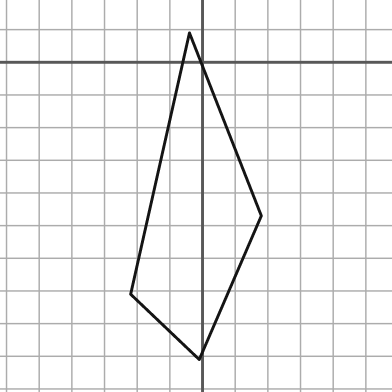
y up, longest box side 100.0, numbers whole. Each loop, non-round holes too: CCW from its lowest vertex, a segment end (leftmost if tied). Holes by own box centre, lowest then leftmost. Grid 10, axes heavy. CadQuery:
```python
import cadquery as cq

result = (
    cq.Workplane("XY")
    .moveTo(-1.0, -91.0)
    .lineTo(18.0, -47.0)
    .lineTo(-4.0, 9.0)
    .lineTo(-22.0, -71.0)
    .close()
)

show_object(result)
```